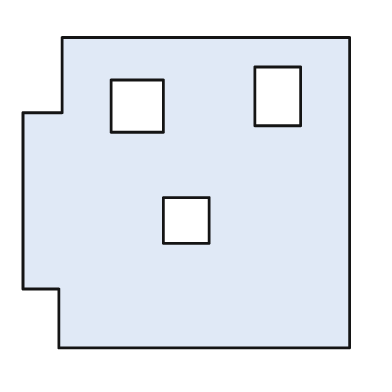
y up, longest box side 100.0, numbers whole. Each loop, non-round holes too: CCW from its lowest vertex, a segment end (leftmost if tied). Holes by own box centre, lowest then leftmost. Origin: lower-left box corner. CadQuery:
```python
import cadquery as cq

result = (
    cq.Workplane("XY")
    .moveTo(11.0, 0.0)
    .lineTo(100.0, 0.0)
    .lineTo(100.0, 95.0)
    .lineTo(12.0, 95.0)
    .lineTo(12.0, 72.0)
    .lineTo(0.0, 72.0)
    .lineTo(0.0, 18.0)
    .lineTo(11.0, 18.0)
    .close()
    .moveTo(43.0, 32.0)
    .lineTo(57.0, 32.0)
    .lineTo(57.0, 46.0)
    .lineTo(43.0, 46.0)
    .close()
    .moveTo(27.0, 66.0)
    .lineTo(43.0, 66.0)
    .lineTo(43.0, 82.0)
    .lineTo(27.0, 82.0)
    .close()
    .moveTo(71.0, 68.0)
    .lineTo(85.0, 68.0)
    .lineTo(85.0, 86.0)
    .lineTo(71.0, 86.0)
    .close()
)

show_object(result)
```